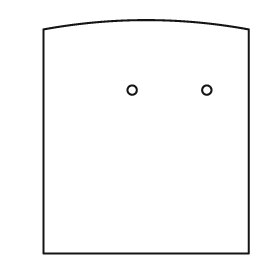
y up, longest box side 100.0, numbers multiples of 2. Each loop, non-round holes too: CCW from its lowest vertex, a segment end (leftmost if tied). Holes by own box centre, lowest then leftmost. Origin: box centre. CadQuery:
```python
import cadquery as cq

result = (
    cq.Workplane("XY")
    .moveTo(-44.0, -50.0)
    .lineTo(44.0, -50.0)
    .lineTo(44.0, 46.0)
    .threePointArc((0.0, 50.0), (-44.0, 46.0))
    .close()
    .moveTo(-6.0, 20.0)
    .circle(2.0)
    .moveTo(26.0, 20.0)
    .circle(2.0)
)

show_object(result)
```